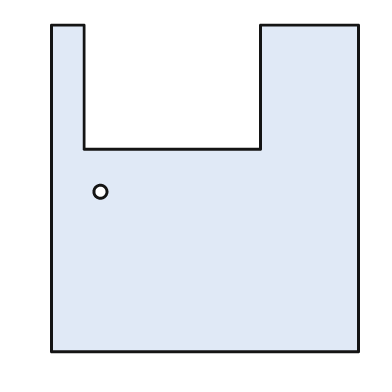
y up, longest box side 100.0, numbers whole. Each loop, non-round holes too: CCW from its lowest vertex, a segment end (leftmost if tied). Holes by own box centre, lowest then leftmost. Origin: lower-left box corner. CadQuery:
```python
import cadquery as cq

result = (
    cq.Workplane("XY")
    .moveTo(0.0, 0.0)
    .lineTo(94.0, 0.0)
    .lineTo(94.0, 100.0)
    .lineTo(64.0, 100.0)
    .lineTo(64.0, 62.0)
    .lineTo(10.0, 62.0)
    .lineTo(10.0, 100.0)
    .lineTo(0.0, 100.0)
    .close()
    .moveTo(15.0, 49.0)
    .circle(2.0)
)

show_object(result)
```